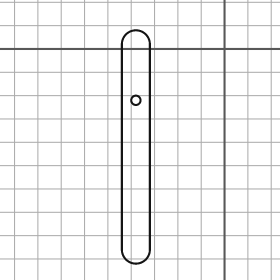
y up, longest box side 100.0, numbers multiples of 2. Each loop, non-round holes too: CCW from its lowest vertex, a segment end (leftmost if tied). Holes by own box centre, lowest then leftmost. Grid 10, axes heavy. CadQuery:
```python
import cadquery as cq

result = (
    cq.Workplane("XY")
    .moveTo(-44.0, -86.0)
    .threePointArc((-38.0, -92.0), (-32.0, -86.0))
    .lineTo(-32.0, 2.0)
    .threePointArc((-38.0, 8.0), (-44.0, 2.0))
    .close()
    .moveTo(-38.0, -22.0)
    .circle(2.0)
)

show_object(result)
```